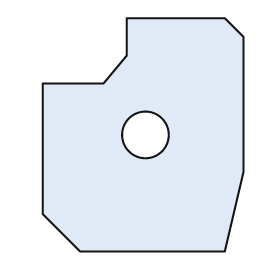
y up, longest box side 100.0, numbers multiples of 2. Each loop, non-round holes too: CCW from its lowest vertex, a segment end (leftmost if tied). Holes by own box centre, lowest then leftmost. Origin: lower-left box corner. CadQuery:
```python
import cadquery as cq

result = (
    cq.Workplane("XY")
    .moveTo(16.0, 0.0)
    .lineTo(78.0, 0.0)
    .lineTo(86.0, 34.0)
    .lineTo(86.0, 92.0)
    .lineTo(78.0, 100.0)
    .lineTo(36.0, 100.0)
    .lineTo(36.0, 84.0)
    .lineTo(26.0, 72.0)
    .lineTo(0.0, 72.0)
    .lineTo(0.0, 16.0)
    .close()
    .moveTo(44.0, 50.0)
    .circle(10.0)
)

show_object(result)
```